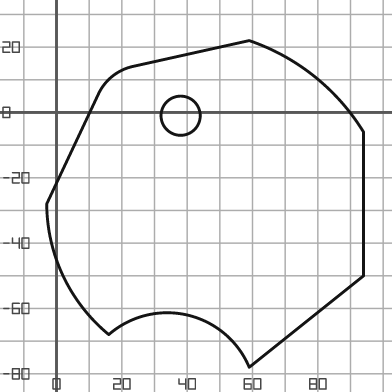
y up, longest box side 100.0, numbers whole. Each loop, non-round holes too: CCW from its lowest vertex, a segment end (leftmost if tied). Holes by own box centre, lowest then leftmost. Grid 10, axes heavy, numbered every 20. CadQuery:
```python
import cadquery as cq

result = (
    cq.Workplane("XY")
    .moveTo(59.0, -78.0)
    .lineTo(94.0, -50.0)
    .lineTo(94.0, -6.0)
    .threePointArc((79.0, 11.0), (59.0, 22.0))
    .lineTo(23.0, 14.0)
    .threePointArc((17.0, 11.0), (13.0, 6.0))
    .lineTo(-3.0, -28.0)
    .threePointArc((2.0, -50.0), (16.0, -68.0))
    .threePointArc((40.0, -62.0), (59.0, -78.0))
    .close()
    .moveTo(38.0, -1.0)
    .circle(6.0)
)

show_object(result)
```